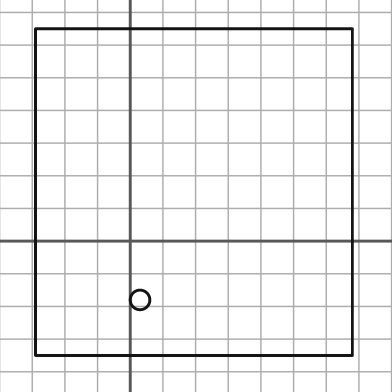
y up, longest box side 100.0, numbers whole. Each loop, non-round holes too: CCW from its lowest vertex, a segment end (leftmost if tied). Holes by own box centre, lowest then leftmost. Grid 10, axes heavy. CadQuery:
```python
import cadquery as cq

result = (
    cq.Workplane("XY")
    .moveTo(-29.0, -35.0)
    .lineTo(68.0, -35.0)
    .lineTo(68.0, 65.0)
    .lineTo(-29.0, 65.0)
    .close()
    .moveTo(3.0, -18.0)
    .circle(3.0)
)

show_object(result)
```